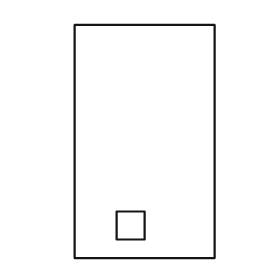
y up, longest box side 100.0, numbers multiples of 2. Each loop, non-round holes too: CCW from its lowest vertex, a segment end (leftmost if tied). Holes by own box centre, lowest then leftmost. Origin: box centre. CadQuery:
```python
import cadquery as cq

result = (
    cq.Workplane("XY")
    .moveTo(-30.0, -50.0)
    .lineTo(30.0, -50.0)
    .lineTo(30.0, 50.0)
    .lineTo(-30.0, 50.0)
    .close()
    .moveTo(-12.0, -42.0)
    .lineTo(0.0, -42.0)
    .lineTo(0.0, -30.0)
    .lineTo(-12.0, -30.0)
    .close()
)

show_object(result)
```